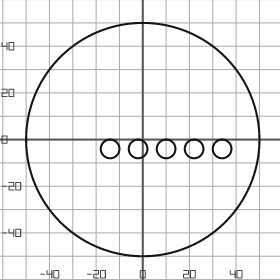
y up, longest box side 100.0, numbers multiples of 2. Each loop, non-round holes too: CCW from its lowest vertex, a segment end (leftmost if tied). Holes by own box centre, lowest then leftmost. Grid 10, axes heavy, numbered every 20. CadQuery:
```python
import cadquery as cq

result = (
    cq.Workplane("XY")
    .moveTo(0.0, 0.0)
    .circle(50.0)
    .moveTo(-14.0, -4.0)
    .circle(4.0)
    .moveTo(-2.0, -4.0)
    .circle(4.0)
    .moveTo(10.0, -4.0)
    .circle(4.0)
    .moveTo(22.0, -4.0)
    .circle(4.0)
    .moveTo(34.0, -4.0)
    .circle(4.0)
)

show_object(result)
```